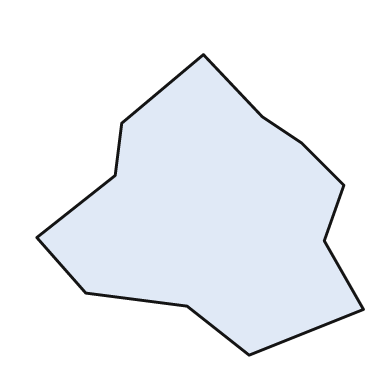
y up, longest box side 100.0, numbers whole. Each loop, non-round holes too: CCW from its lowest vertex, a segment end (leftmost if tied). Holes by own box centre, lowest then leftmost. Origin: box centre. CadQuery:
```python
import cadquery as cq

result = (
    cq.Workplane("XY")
    .moveTo(15.0, -46.0)
    .lineTo(50.0, -32.0)
    .lineTo(38.0, -11.0)
    .lineTo(44.0, 6.0)
    .lineTo(31.0, 19.0)
    .lineTo(19.0, 27.0)
    .lineTo(1.0, 46.0)
    .lineTo(-24.0, 25.0)
    .lineTo(-26.0, 9.0)
    .lineTo(-50.0, -10.0)
    .lineTo(-35.0, -27.0)
    .lineTo(-4.0, -31.0)
    .close()
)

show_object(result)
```